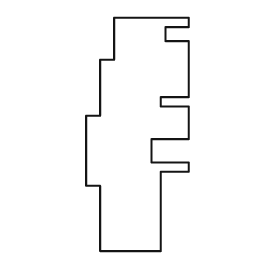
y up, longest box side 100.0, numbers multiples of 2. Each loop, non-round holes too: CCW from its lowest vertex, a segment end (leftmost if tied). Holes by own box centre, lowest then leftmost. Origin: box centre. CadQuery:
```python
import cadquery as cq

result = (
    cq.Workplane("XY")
    .moveTo(-16.0, -50.0)
    .lineTo(10.0, -50.0)
    .lineTo(10.0, -16.0)
    .lineTo(22.0, -16.0)
    .lineTo(22.0, -12.0)
    .lineTo(6.0, -12.0)
    .lineTo(6.0, -2.0)
    .lineTo(22.0, -2.0)
    .lineTo(22.0, 12.0)
    .lineTo(10.0, 12.0)
    .lineTo(10.0, 16.0)
    .lineTo(22.0, 16.0)
    .lineTo(22.0, 40.0)
    .lineTo(12.0, 40.0)
    .lineTo(12.0, 46.0)
    .lineTo(22.0, 46.0)
    .lineTo(22.0, 50.0)
    .lineTo(-10.0, 50.0)
    .lineTo(-10.0, 32.0)
    .lineTo(-16.0, 32.0)
    .lineTo(-16.0, 8.0)
    .lineTo(-22.0, 8.0)
    .lineTo(-22.0, -22.0)
    .lineTo(-16.0, -22.0)
    .close()
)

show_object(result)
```